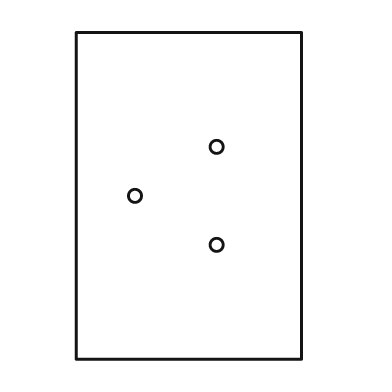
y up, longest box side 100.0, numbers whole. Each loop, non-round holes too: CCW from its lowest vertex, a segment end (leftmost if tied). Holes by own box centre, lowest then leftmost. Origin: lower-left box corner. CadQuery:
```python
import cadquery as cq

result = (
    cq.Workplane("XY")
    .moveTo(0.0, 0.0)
    .lineTo(69.0, 0.0)
    .lineTo(69.0, 100.0)
    .lineTo(0.0, 100.0)
    .close()
    .moveTo(43.0, 35.0)
    .circle(2.0)
    .moveTo(18.0, 50.0)
    .circle(2.0)
    .moveTo(43.0, 65.0)
    .circle(2.0)
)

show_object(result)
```